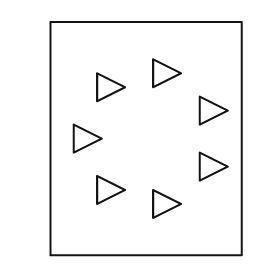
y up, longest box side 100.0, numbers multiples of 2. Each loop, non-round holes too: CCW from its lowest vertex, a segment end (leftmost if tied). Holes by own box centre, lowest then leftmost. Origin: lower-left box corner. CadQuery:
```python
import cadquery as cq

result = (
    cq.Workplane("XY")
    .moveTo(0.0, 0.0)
    .lineTo(82.0, 0.0)
    .lineTo(82.0, 100.0)
    .lineTo(0.0, 100.0)
    .close()
    .moveTo(44.0, 16.0)
    .lineTo(56.0, 22.0)
    .lineTo(44.0, 28.0)
    .close()
    .moveTo(20.0, 22.0)
    .lineTo(32.0, 28.0)
    .lineTo(20.0, 34.0)
    .close()
    .moveTo(64.0, 32.0)
    .lineTo(76.0, 38.0)
    .lineTo(64.0, 44.0)
    .close()
    .moveTo(10.0, 44.0)
    .lineTo(22.0, 50.0)
    .lineTo(10.0, 56.0)
    .close()
    .moveTo(64.0, 56.0)
    .lineTo(76.0, 62.0)
    .lineTo(64.0, 68.0)
    .close()
    .moveTo(20.0, 66.0)
    .lineTo(32.0, 72.0)
    .lineTo(20.0, 78.0)
    .close()
    .moveTo(44.0, 72.0)
    .lineTo(56.0, 78.0)
    .lineTo(44.0, 84.0)
    .close()
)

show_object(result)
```